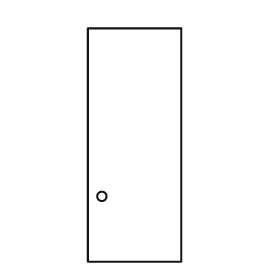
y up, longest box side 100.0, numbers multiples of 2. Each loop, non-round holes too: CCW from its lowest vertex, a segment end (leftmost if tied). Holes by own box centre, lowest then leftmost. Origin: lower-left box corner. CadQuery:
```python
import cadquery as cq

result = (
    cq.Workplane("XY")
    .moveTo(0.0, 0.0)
    .lineTo(40.0, 0.0)
    .lineTo(40.0, 100.0)
    .lineTo(0.0, 100.0)
    .close()
    .moveTo(6.0, 28.0)
    .circle(2.0)
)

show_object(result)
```